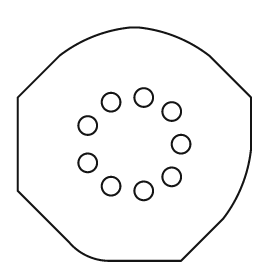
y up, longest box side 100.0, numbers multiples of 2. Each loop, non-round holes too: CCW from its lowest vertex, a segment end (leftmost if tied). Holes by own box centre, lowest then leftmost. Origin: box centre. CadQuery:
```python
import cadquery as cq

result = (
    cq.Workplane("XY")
    .moveTo(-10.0, -50.0)
    .lineTo(20.0, -50.0)
    .lineTo(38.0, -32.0)
    .threePointArc((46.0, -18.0), (50.0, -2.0))
    .lineTo(50.0, 20.0)
    .lineTo(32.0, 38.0)
    .threePointArc((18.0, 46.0), (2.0, 50.0))
    .lineTo(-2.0, 50.0)
    .threePointArc((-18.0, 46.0), (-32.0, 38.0))
    .lineTo(-50.0, 20.0)
    .lineTo(-50.0, -20.0)
    .lineTo(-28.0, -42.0)
    .threePointArc((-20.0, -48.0), (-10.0, -50.0))
    .close()
    .moveTo(4.0, -20.0)
    .circle(4.0)
    .moveTo(-10.0, -18.0)
    .circle(4.0)
    .moveTo(16.0, -14.0)
    .circle(4.0)
    .moveTo(-20.0, -8.0)
    .circle(4.0)
    .moveTo(20.0, 0.0)
    .circle(4.0)
    .moveTo(-20.0, 8.0)
    .circle(4.0)
    .moveTo(16.0, 14.0)
    .circle(4.0)
    .moveTo(-10.0, 18.0)
    .circle(4.0)
    .moveTo(4.0, 20.0)
    .circle(4.0)
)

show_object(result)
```